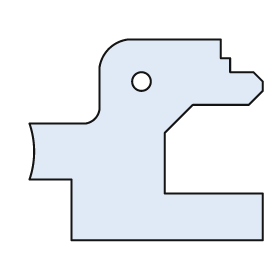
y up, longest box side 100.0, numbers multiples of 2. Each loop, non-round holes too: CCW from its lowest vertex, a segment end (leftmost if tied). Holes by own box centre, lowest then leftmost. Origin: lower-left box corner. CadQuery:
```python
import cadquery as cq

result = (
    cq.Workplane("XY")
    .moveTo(18.0, 0.0)
    .lineTo(100.0, 0.0)
    .lineTo(100.0, 20.0)
    .lineTo(58.0, 20.0)
    .lineTo(58.0, 46.0)
    .lineTo(70.0, 58.0)
    .lineTo(94.0, 58.0)
    .lineTo(100.0, 64.0)
    .lineTo(100.0, 68.0)
    .lineTo(96.0, 72.0)
    .lineTo(86.0, 72.0)
    .lineTo(86.0, 78.0)
    .lineTo(82.0, 78.0)
    .lineTo(82.0, 86.0)
    .lineTo(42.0, 86.0)
    .threePointArc((34.0, 82.0), (30.0, 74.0))
    .lineTo(30.0, 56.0)
    .threePointArc((28.0, 52.0), (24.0, 50.0))
    .lineTo(0.0, 50.0)
    .threePointArc((2.0, 38.0), (0.0, 26.0))
    .lineTo(18.0, 26.0)
    .close()
    .moveTo(48.0, 68.0)
    .circle(4.0)
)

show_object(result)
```